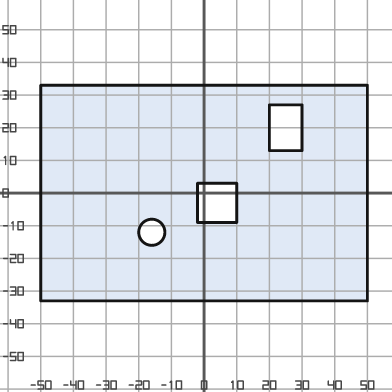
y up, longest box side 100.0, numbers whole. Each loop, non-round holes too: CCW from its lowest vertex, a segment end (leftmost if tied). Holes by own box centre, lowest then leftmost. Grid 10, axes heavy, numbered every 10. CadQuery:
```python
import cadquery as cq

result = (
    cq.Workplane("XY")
    .moveTo(-50.0, -33.0)
    .lineTo(50.0, -33.0)
    .lineTo(50.0, 33.0)
    .lineTo(-50.0, 33.0)
    .close()
    .moveTo(-16.0, -12.0)
    .circle(4.0)
    .moveTo(-2.0, -9.0)
    .lineTo(10.0, -9.0)
    .lineTo(10.0, 3.0)
    .lineTo(-2.0, 3.0)
    .close()
    .moveTo(20.0, 13.0)
    .lineTo(30.0, 13.0)
    .lineTo(30.0, 27.0)
    .lineTo(20.0, 27.0)
    .close()
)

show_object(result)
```